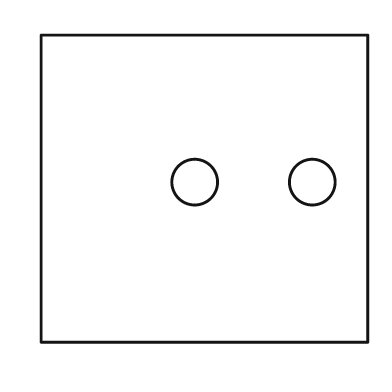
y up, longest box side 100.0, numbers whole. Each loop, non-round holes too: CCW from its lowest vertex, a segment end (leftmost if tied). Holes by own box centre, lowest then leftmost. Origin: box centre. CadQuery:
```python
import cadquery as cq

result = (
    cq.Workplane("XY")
    .moveTo(-50.0, -47.0)
    .lineTo(50.0, -47.0)
    .lineTo(50.0, 47.0)
    .lineTo(-50.0, 47.0)
    .close()
    .moveTo(-3.0, 2.0)
    .circle(7.0)
    .moveTo(33.0, 2.0)
    .circle(7.0)
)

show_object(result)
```